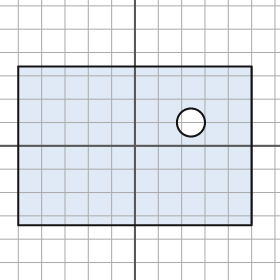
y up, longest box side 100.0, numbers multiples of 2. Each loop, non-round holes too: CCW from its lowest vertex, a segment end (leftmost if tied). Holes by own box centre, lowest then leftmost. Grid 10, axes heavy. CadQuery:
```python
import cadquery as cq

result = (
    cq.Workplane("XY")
    .moveTo(-50.0, -34.0)
    .lineTo(50.0, -34.0)
    .lineTo(50.0, 34.0)
    .lineTo(-50.0, 34.0)
    .close()
    .moveTo(24.0, 10.0)
    .circle(6.0)
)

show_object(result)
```